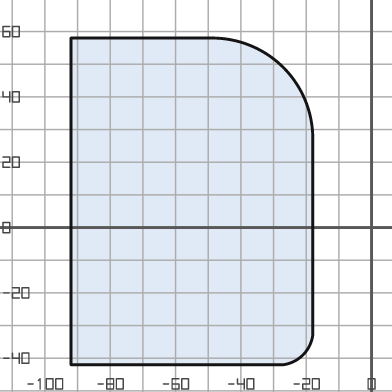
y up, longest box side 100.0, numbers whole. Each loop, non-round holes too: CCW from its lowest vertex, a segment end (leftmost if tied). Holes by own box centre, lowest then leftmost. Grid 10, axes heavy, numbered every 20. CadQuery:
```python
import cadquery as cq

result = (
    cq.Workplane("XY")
    .moveTo(-92.0, -42.0)
    .lineTo(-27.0, -42.0)
    .threePointArc((-21.0, -39.0), (-18.0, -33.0))
    .lineTo(-18.0, 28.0)
    .threePointArc((-27.0, 49.0), (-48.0, 58.0))
    .lineTo(-92.0, 58.0)
    .close()
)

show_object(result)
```